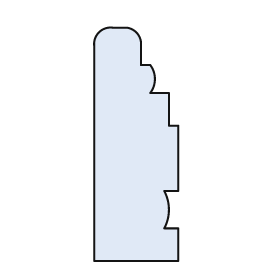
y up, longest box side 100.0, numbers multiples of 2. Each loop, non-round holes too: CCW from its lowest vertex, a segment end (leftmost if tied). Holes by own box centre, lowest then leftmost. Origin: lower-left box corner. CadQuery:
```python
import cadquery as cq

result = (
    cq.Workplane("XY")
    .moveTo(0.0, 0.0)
    .lineTo(36.0, 0.0)
    .lineTo(36.0, 14.0)
    .lineTo(30.0, 14.0)
    .threePointArc((32.0, 22.0), (30.0, 30.0))
    .lineTo(36.0, 30.0)
    .lineTo(36.0, 58.0)
    .lineTo(32.0, 58.0)
    .lineTo(32.0, 72.0)
    .lineTo(24.0, 72.0)
    .threePointArc((26.0, 78.0), (24.0, 84.0))
    .lineTo(20.0, 84.0)
    .lineTo(20.0, 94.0)
    .threePointArc((18.0, 98.0), (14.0, 100.0))
    .lineTo(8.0, 100.0)
    .threePointArc((2.0, 98.0), (0.0, 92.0))
    .close()
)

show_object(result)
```